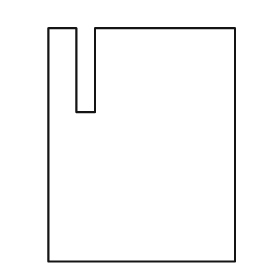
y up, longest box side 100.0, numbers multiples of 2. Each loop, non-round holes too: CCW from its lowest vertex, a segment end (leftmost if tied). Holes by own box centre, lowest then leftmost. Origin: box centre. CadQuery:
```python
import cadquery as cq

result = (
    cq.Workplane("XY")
    .moveTo(-40.0, -50.0)
    .lineTo(40.0, -50.0)
    .lineTo(40.0, 50.0)
    .lineTo(-20.0, 50.0)
    .lineTo(-20.0, 14.0)
    .lineTo(-28.0, 14.0)
    .lineTo(-28.0, 50.0)
    .lineTo(-40.0, 50.0)
    .close()
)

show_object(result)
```